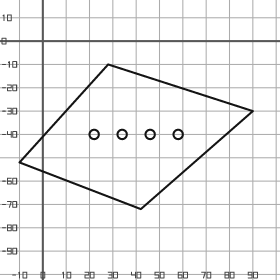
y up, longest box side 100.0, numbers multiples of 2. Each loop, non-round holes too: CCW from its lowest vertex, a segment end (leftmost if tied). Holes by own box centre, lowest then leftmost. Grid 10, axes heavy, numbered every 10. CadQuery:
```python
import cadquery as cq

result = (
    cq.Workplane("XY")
    .moveTo(42.0, -72.0)
    .lineTo(90.0, -30.0)
    .lineTo(28.0, -10.0)
    .lineTo(-10.0, -52.0)
    .close()
    .moveTo(22.0, -40.0)
    .circle(2.0)
    .moveTo(34.0, -40.0)
    .circle(2.0)
    .moveTo(46.0, -40.0)
    .circle(2.0)
    .moveTo(58.0, -40.0)
    .circle(2.0)
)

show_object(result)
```